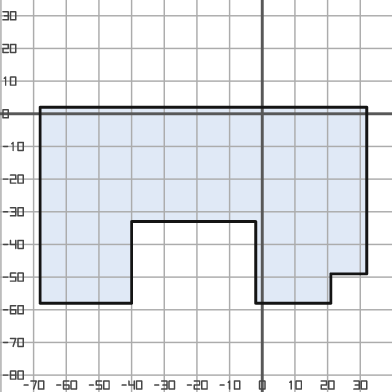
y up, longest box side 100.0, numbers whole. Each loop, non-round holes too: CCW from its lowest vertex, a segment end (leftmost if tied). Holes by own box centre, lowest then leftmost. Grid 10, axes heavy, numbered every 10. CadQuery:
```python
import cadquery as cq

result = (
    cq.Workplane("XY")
    .moveTo(-68.0, -58.0)
    .lineTo(-40.0, -58.0)
    .lineTo(-40.0, -33.0)
    .lineTo(-2.0, -33.0)
    .lineTo(-2.0, -58.0)
    .lineTo(21.0, -58.0)
    .lineTo(21.0, -49.0)
    .lineTo(32.0, -49.0)
    .lineTo(32.0, 2.0)
    .lineTo(-68.0, 2.0)
    .close()
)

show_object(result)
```